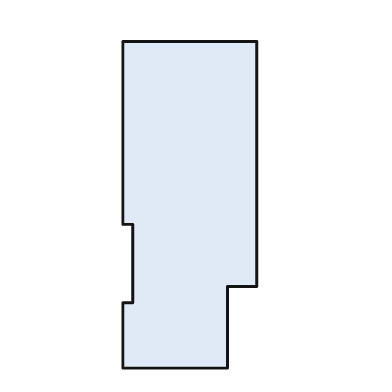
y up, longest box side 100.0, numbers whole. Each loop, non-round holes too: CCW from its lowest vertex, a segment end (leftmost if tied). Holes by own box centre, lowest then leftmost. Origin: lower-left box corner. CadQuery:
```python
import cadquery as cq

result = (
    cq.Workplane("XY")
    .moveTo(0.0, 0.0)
    .lineTo(32.0, 0.0)
    .lineTo(32.0, 25.0)
    .lineTo(41.0, 25.0)
    .lineTo(41.0, 100.0)
    .lineTo(0.0, 100.0)
    .lineTo(0.0, 44.0)
    .lineTo(3.0, 44.0)
    .lineTo(3.0, 20.0)
    .lineTo(0.0, 20.0)
    .close()
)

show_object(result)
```